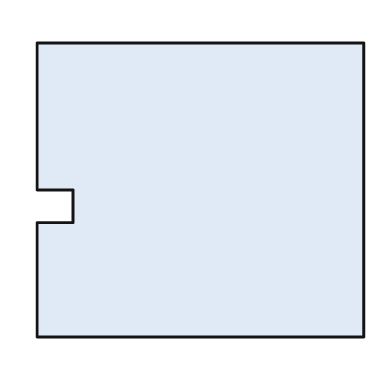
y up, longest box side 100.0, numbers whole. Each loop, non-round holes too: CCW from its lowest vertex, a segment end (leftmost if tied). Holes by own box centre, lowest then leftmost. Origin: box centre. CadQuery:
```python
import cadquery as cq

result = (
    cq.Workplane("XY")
    .moveTo(-50.0, -45.0)
    .lineTo(50.0, -45.0)
    .lineTo(50.0, 45.0)
    .lineTo(-50.0, 45.0)
    .lineTo(-50.0, 0.0)
    .lineTo(-39.0, 0.0)
    .lineTo(-39.0, -10.0)
    .lineTo(-50.0, -10.0)
    .close()
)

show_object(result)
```